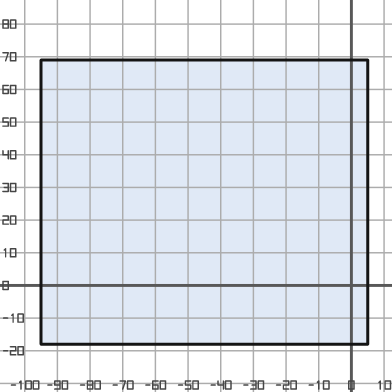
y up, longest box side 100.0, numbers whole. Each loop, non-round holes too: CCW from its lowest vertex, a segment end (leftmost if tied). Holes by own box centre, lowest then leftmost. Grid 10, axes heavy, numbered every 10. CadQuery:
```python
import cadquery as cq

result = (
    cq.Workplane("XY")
    .moveTo(-95.0, -18.0)
    .lineTo(5.0, -18.0)
    .lineTo(5.0, 69.0)
    .lineTo(-95.0, 69.0)
    .close()
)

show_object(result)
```